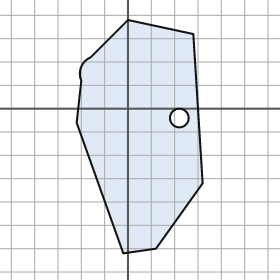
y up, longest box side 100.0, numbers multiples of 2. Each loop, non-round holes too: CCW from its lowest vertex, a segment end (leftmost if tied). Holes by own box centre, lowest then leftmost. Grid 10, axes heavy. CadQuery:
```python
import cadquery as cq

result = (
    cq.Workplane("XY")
    .moveTo(-2.0, -62.0)
    .lineTo(12.0, -60.0)
    .lineTo(32.0, -32.0)
    .lineTo(28.0, 32.0)
    .lineTo(0.0, 38.0)
    .lineTo(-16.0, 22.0)
    .threePointArc((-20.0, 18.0), (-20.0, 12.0))
    .lineTo(-22.0, -6.0)
    .close()
    .moveTo(22.0, -4.0)
    .circle(4.0)
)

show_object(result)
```